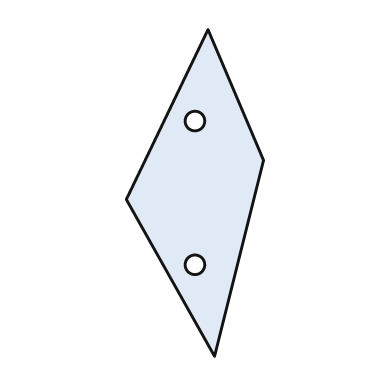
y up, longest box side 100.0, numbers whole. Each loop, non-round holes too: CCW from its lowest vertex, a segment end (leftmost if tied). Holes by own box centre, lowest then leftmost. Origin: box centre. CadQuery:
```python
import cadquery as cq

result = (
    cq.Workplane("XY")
    .moveTo(6.0, -50.0)
    .lineTo(21.0, 10.0)
    .lineTo(4.0, 50.0)
    .lineTo(-21.0, -2.0)
    .close()
    .moveTo(0.0, -22.0)
    .circle(3.0)
    .moveTo(0.0, 22.0)
    .circle(3.0)
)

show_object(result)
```